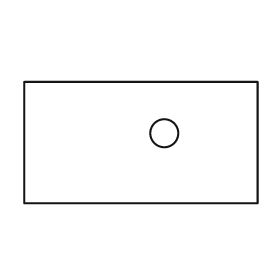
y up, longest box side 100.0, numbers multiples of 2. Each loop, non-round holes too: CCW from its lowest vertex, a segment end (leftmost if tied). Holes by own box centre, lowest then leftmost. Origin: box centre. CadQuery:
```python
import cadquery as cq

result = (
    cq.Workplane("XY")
    .moveTo(-50.0, -26.0)
    .lineTo(50.0, -26.0)
    .lineTo(50.0, 26.0)
    .lineTo(-50.0, 26.0)
    .close()
    .moveTo(10.0, 4.0)
    .circle(6.0)
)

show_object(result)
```